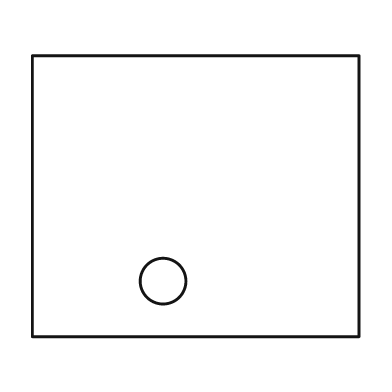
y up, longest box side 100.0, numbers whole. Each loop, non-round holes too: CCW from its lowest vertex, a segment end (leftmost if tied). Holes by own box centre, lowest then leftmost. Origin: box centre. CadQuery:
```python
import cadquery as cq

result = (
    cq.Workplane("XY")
    .moveTo(-50.0, -43.0)
    .lineTo(50.0, -43.0)
    .lineTo(50.0, 43.0)
    .lineTo(-50.0, 43.0)
    .close()
    .moveTo(-10.0, -26.0)
    .circle(7.0)
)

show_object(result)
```